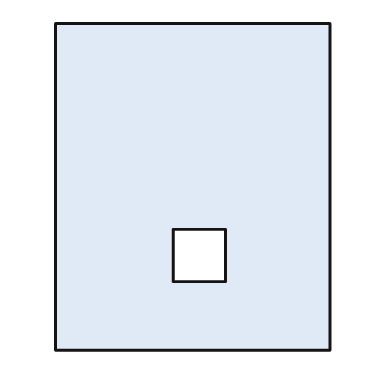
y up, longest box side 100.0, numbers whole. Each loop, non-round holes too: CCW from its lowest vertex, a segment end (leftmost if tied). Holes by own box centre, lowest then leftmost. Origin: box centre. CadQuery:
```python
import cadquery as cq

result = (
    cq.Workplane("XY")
    .moveTo(-42.0, -50.0)
    .lineTo(42.0, -50.0)
    .lineTo(42.0, 50.0)
    .lineTo(-42.0, 50.0)
    .close()
    .moveTo(-6.0, -29.0)
    .lineTo(10.0, -29.0)
    .lineTo(10.0, -13.0)
    .lineTo(-6.0, -13.0)
    .close()
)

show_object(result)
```